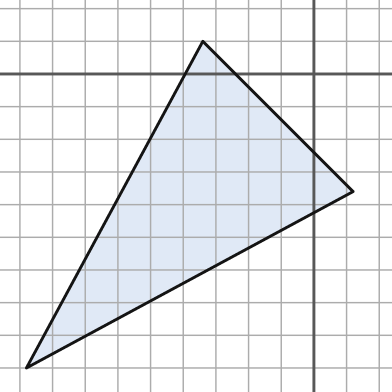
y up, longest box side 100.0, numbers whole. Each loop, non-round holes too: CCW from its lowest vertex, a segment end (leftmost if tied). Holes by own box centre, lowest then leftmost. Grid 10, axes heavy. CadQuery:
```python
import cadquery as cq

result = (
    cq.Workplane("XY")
    .moveTo(-88.0, -90.0)
    .lineTo(12.0, -36.0)
    .lineTo(-34.0, 10.0)
    .close()
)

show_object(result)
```